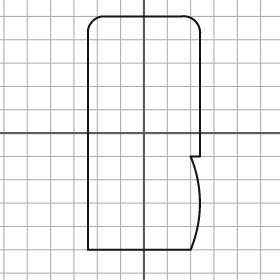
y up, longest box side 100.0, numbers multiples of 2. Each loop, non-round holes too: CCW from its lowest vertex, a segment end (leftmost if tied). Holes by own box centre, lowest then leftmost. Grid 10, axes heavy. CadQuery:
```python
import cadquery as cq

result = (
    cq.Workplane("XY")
    .moveTo(-24.0, -50.0)
    .lineTo(20.0, -50.0)
    .threePointArc((24.0, -30.0), (20.0, -10.0))
    .lineTo(24.0, -10.0)
    .lineTo(24.0, 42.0)
    .threePointArc((22.0, 48.0), (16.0, 50.0))
    .lineTo(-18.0, 50.0)
    .threePointArc((-22.0, 48.0), (-24.0, 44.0))
    .close()
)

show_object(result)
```